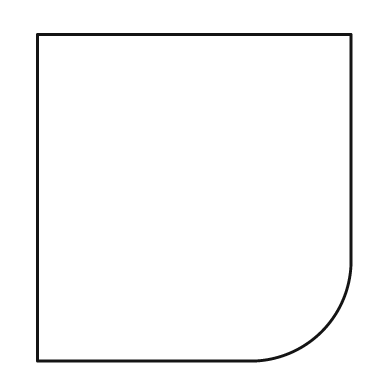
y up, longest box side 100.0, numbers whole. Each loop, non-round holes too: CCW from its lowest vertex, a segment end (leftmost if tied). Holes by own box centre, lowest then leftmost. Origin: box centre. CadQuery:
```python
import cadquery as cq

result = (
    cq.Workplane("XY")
    .moveTo(-48.0, -50.0)
    .lineTo(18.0, -50.0)
    .threePointArc((39.0, -41.0), (48.0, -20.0))
    .lineTo(48.0, 50.0)
    .lineTo(-48.0, 50.0)
    .close()
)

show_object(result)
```